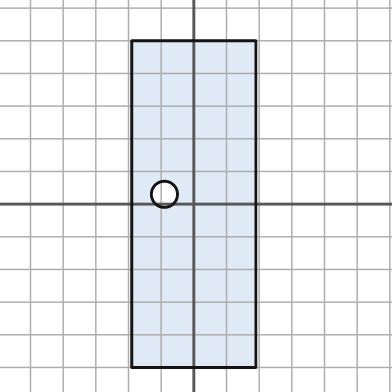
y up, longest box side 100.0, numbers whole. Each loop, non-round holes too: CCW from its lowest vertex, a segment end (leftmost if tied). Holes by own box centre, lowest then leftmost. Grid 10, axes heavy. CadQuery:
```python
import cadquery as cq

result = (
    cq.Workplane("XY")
    .moveTo(-19.0, -50.0)
    .lineTo(19.0, -50.0)
    .lineTo(19.0, 50.0)
    .lineTo(-19.0, 50.0)
    .close()
    .moveTo(-9.0, 3.0)
    .circle(4.0)
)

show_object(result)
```